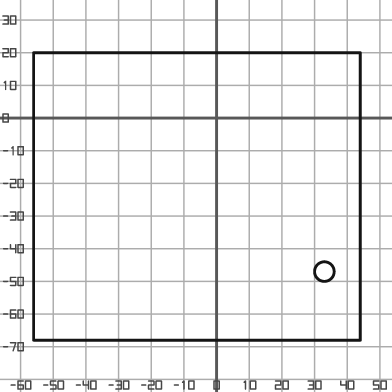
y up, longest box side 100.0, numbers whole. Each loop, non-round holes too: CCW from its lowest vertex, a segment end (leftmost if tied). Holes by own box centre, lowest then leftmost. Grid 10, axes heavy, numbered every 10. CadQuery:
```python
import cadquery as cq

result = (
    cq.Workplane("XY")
    .moveTo(-56.0, -68.0)
    .lineTo(44.0, -68.0)
    .lineTo(44.0, 20.0)
    .lineTo(-56.0, 20.0)
    .close()
    .moveTo(33.0, -47.0)
    .circle(3.0)
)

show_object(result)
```